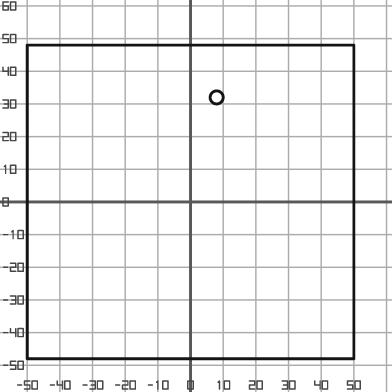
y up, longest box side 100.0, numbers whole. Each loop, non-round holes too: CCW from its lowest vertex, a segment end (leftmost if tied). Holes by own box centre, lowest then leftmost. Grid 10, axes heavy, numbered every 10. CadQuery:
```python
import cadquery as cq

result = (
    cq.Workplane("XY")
    .moveTo(-50.0, -48.0)
    .lineTo(50.0, -48.0)
    .lineTo(50.0, 48.0)
    .lineTo(-50.0, 48.0)
    .close()
    .moveTo(8.0, 32.0)
    .circle(2.0)
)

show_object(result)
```